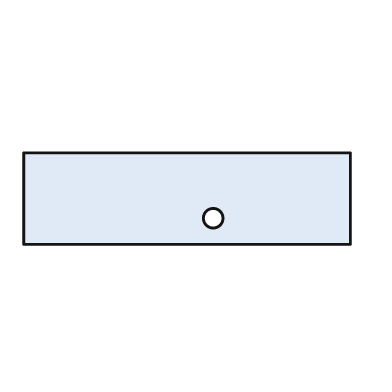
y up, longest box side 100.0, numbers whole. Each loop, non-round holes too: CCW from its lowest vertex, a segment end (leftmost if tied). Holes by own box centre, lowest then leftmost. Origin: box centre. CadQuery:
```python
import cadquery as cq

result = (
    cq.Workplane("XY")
    .moveTo(-50.0, -14.0)
    .lineTo(50.0, -14.0)
    .lineTo(50.0, 14.0)
    .lineTo(-50.0, 14.0)
    .close()
    .moveTo(8.0, -6.0)
    .circle(3.0)
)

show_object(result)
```